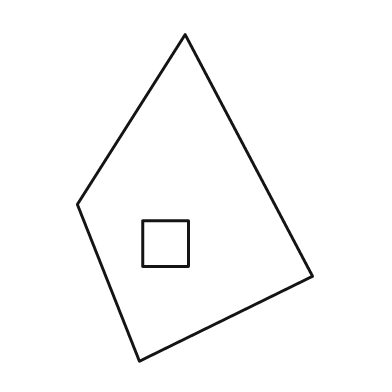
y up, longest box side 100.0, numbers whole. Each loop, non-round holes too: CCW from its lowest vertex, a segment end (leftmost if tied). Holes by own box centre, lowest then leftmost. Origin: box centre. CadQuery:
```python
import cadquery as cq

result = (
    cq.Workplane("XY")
    .moveTo(-17.0, -50.0)
    .lineTo(36.0, -24.0)
    .lineTo(-3.0, 50.0)
    .lineTo(-36.0, -2.0)
    .close()
    .moveTo(-16.0, -21.0)
    .lineTo(-2.0, -21.0)
    .lineTo(-2.0, -7.0)
    .lineTo(-16.0, -7.0)
    .close()
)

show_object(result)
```